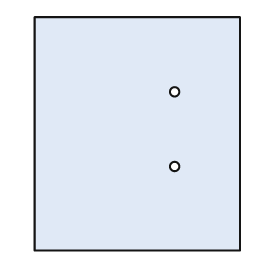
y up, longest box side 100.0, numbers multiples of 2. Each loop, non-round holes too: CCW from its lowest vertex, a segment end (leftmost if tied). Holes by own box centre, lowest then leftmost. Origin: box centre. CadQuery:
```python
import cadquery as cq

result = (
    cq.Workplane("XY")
    .moveTo(-44.0, -50.0)
    .lineTo(44.0, -50.0)
    .lineTo(44.0, 50.0)
    .lineTo(-44.0, 50.0)
    .close()
    .moveTo(16.0, -14.0)
    .circle(2.0)
    .moveTo(16.0, 18.0)
    .circle(2.0)
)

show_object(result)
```